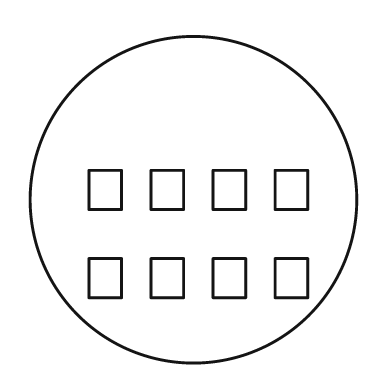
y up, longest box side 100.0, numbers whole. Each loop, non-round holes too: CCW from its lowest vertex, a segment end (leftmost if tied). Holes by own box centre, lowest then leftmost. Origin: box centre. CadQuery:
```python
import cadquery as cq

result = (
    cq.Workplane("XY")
    .moveTo(0.0, 0.0)
    .circle(50.0)
    .moveTo(-32.0, -30.0)
    .lineTo(-22.0, -30.0)
    .lineTo(-22.0, -18.0)
    .lineTo(-32.0, -18.0)
    .close()
    .moveTo(-13.0, -30.0)
    .lineTo(-3.0, -30.0)
    .lineTo(-3.0, -18.0)
    .lineTo(-13.0, -18.0)
    .close()
    .moveTo(6.0, -30.0)
    .lineTo(16.0, -30.0)
    .lineTo(16.0, -18.0)
    .lineTo(6.0, -18.0)
    .close()
    .moveTo(25.0, -30.0)
    .lineTo(35.0, -30.0)
    .lineTo(35.0, -18.0)
    .lineTo(25.0, -18.0)
    .close()
    .moveTo(-32.0, -3.0)
    .lineTo(-22.0, -3.0)
    .lineTo(-22.0, 9.0)
    .lineTo(-32.0, 9.0)
    .close()
    .moveTo(-13.0, -3.0)
    .lineTo(-3.0, -3.0)
    .lineTo(-3.0, 9.0)
    .lineTo(-13.0, 9.0)
    .close()
    .moveTo(6.0, -3.0)
    .lineTo(16.0, -3.0)
    .lineTo(16.0, 9.0)
    .lineTo(6.0, 9.0)
    .close()
    .moveTo(25.0, -3.0)
    .lineTo(35.0, -3.0)
    .lineTo(35.0, 9.0)
    .lineTo(25.0, 9.0)
    .close()
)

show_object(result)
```